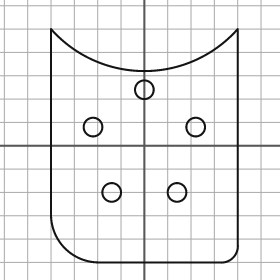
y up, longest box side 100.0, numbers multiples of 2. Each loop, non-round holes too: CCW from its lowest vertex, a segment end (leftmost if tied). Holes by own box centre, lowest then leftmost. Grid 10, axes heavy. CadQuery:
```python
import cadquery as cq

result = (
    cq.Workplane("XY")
    .moveTo(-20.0, -50.0)
    .lineTo(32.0, -50.0)
    .threePointArc((38.0, -48.0), (40.0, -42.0))
    .lineTo(40.0, 50.0)
    .threePointArc((0.0, 32.0), (-40.0, 50.0))
    .lineTo(-40.0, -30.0)
    .threePointArc((-34.0, -44.0), (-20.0, -50.0))
    .close()
    .moveTo(-14.0, -20.0)
    .circle(4.0)
    .moveTo(14.0, -20.0)
    .circle(4.0)
    .moveTo(-22.0, 8.0)
    .circle(4.0)
    .moveTo(22.0, 8.0)
    .circle(4.0)
    .moveTo(0.0, 24.0)
    .circle(4.0)
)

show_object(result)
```